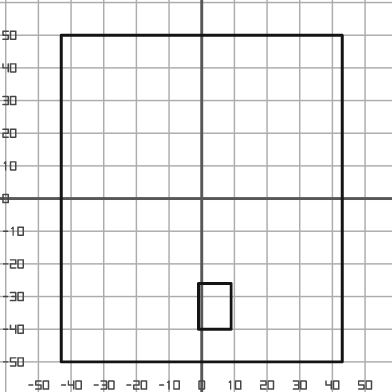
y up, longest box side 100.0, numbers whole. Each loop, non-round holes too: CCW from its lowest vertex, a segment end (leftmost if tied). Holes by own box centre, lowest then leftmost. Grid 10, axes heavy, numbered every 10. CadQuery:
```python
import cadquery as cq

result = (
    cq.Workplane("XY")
    .moveTo(-43.0, -50.0)
    .lineTo(43.0, -50.0)
    .lineTo(43.0, 50.0)
    .lineTo(-43.0, 50.0)
    .close()
    .moveTo(-1.0, -40.0)
    .lineTo(9.0, -40.0)
    .lineTo(9.0, -26.0)
    .lineTo(-1.0, -26.0)
    .close()
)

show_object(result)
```